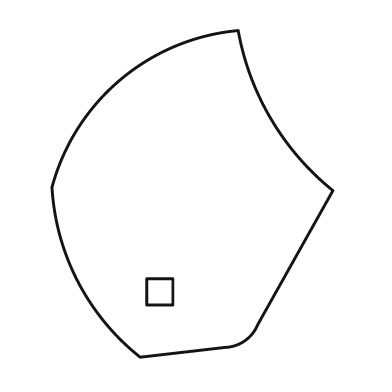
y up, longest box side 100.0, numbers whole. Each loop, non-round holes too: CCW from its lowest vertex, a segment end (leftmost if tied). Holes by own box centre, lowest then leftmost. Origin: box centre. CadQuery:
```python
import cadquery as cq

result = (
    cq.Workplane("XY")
    .moveTo(-16.0, -50.0)
    .lineTo(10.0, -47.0)
    .threePointArc((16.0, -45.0), (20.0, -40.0))
    .lineTo(43.0, 1.0)
    .threePointArc((24.0, 23.0), (14.0, 50.0))
    .threePointArc((-22.0, 35.0), (-43.0, 2.0))
    .threePointArc((-35.0, -27.0), (-16.0, -50.0))
    .close()
    .moveTo(-14.0, -34.0)
    .lineTo(-6.0, -34.0)
    .lineTo(-6.0, -26.0)
    .lineTo(-14.0, -26.0)
    .close()
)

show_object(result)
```